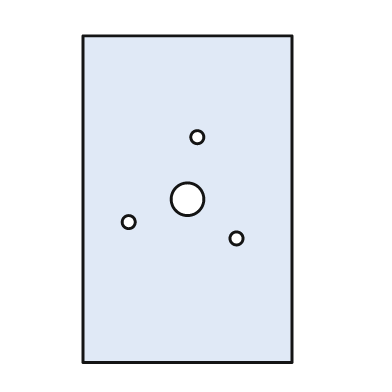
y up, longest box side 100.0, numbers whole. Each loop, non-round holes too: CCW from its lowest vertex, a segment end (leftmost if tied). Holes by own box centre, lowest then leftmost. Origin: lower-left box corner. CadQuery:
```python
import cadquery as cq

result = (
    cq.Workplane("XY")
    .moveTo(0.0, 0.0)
    .lineTo(64.0, 0.0)
    .lineTo(64.0, 100.0)
    .lineTo(0.0, 100.0)
    .close()
    .moveTo(47.0, 38.0)
    .circle(2.0)
    .moveTo(14.0, 43.0)
    .circle(2.0)
    .moveTo(32.0, 50.0)
    .circle(5.0)
    .moveTo(35.0, 69.0)
    .circle(2.0)
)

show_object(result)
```